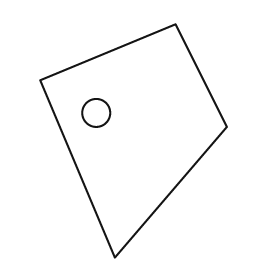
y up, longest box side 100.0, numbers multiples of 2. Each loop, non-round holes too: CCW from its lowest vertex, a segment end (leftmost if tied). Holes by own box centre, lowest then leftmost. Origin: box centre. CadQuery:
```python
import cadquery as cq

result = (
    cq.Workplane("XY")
    .moveTo(-8.0, -50.0)
    .lineTo(40.0, 6.0)
    .lineTo(18.0, 50.0)
    .lineTo(-40.0, 26.0)
    .close()
    .moveTo(-16.0, 12.0)
    .circle(6.0)
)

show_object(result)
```